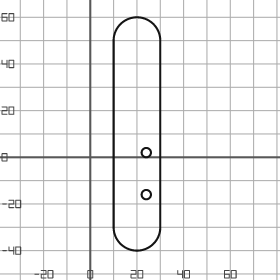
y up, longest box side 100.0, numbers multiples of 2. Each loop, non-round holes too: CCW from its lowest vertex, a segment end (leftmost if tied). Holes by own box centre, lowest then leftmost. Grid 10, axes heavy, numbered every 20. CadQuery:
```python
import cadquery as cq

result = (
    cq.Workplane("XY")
    .moveTo(10.0, -30.0)
    .threePointArc((20.0, -40.0), (30.0, -30.0))
    .lineTo(30.0, 50.0)
    .threePointArc((20.0, 60.0), (10.0, 50.0))
    .close()
    .moveTo(24.0, -16.0)
    .circle(2.0)
    .moveTo(24.0, 2.0)
    .circle(2.0)
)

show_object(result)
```